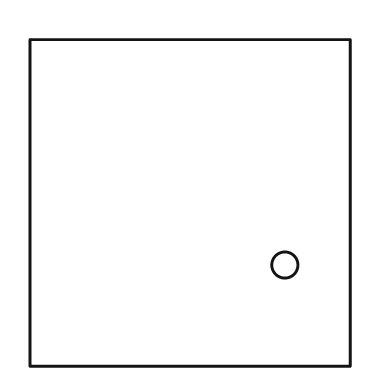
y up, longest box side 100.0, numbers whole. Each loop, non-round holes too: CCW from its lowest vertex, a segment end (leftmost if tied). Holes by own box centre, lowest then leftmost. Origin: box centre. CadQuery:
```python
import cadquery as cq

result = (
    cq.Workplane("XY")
    .moveTo(-49.0, -50.0)
    .lineTo(49.0, -50.0)
    .lineTo(49.0, 50.0)
    .lineTo(-49.0, 50.0)
    .close()
    .moveTo(29.0, -19.0)
    .circle(4.0)
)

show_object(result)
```